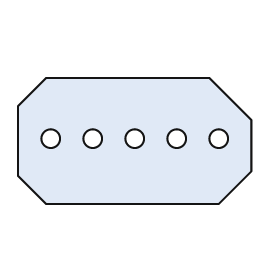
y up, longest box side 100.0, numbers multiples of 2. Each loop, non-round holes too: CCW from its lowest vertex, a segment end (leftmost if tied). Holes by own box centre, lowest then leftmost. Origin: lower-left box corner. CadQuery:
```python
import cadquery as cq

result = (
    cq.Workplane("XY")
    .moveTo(12.0, 0.0)
    .lineTo(86.0, 0.0)
    .lineTo(100.0, 14.0)
    .lineTo(100.0, 36.0)
    .lineTo(82.0, 54.0)
    .lineTo(12.0, 54.0)
    .lineTo(0.0, 42.0)
    .lineTo(0.0, 12.0)
    .close()
    .moveTo(14.0, 28.0)
    .circle(4.0)
    .moveTo(32.0, 28.0)
    .circle(4.0)
    .moveTo(50.0, 28.0)
    .circle(4.0)
    .moveTo(68.0, 28.0)
    .circle(4.0)
    .moveTo(86.0, 28.0)
    .circle(4.0)
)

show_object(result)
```